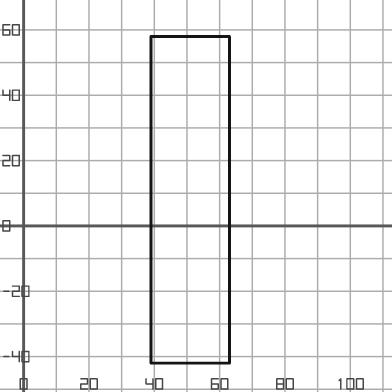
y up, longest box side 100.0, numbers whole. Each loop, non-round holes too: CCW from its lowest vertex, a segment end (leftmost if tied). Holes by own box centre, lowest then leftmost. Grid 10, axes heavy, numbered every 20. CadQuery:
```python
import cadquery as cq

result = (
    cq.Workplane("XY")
    .moveTo(39.0, -42.0)
    .lineTo(63.0, -42.0)
    .lineTo(63.0, 58.0)
    .lineTo(39.0, 58.0)
    .close()
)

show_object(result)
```